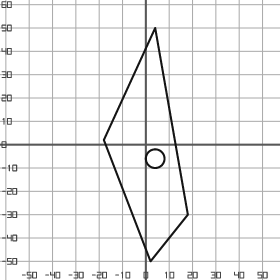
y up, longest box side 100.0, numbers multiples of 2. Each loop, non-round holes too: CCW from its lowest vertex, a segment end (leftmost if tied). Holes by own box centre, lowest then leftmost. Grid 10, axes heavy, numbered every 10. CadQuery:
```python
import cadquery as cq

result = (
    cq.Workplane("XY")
    .moveTo(2.0, -50.0)
    .lineTo(18.0, -30.0)
    .lineTo(4.0, 50.0)
    .lineTo(-18.0, 2.0)
    .close()
    .moveTo(4.0, -6.0)
    .circle(4.0)
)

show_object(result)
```